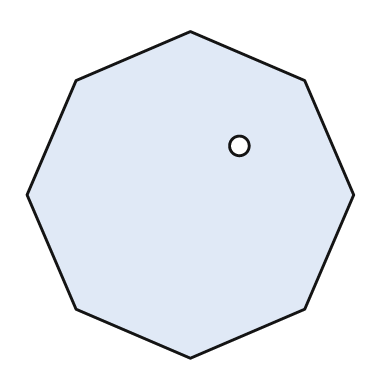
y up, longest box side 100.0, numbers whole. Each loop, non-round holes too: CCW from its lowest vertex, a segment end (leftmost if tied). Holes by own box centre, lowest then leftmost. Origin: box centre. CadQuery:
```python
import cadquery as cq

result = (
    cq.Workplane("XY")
    .moveTo(0.0, -50.0)
    .lineTo(35.0, -35.0)
    .lineTo(50.0, 0.0)
    .lineTo(35.0, 35.0)
    .lineTo(0.0, 50.0)
    .lineTo(-35.0, 35.0)
    .lineTo(-50.0, 0.0)
    .lineTo(-35.0, -35.0)
    .close()
    .moveTo(15.0, 15.0)
    .circle(3.0)
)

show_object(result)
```